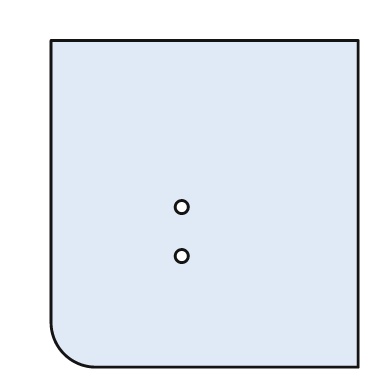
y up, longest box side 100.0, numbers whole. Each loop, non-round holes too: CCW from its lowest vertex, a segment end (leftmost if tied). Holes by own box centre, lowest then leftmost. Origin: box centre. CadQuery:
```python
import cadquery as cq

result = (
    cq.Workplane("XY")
    .moveTo(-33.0, -50.0)
    .lineTo(47.0, -50.0)
    .lineTo(47.0, 50.0)
    .lineTo(-47.0, 50.0)
    .lineTo(-47.0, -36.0)
    .threePointArc((-43.0, -46.0), (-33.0, -50.0))
    .close()
    .moveTo(-7.0, -16.0)
    .circle(2.0)
    .moveTo(-7.0, -1.0)
    .circle(2.0)
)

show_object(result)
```